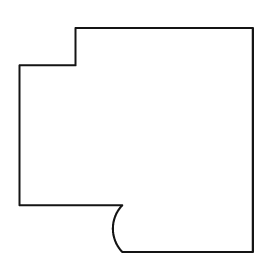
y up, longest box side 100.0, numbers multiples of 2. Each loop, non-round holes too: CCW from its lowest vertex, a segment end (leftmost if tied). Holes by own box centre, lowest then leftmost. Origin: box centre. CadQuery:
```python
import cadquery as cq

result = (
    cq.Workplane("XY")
    .moveTo(-6.0, -48.0)
    .lineTo(50.0, -48.0)
    .lineTo(50.0, 48.0)
    .lineTo(-26.0, 48.0)
    .lineTo(-26.0, 32.0)
    .lineTo(-50.0, 32.0)
    .lineTo(-50.0, -28.0)
    .lineTo(-6.0, -28.0)
    .threePointArc((-10.0, -38.0), (-6.0, -48.0))
    .close()
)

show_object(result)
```